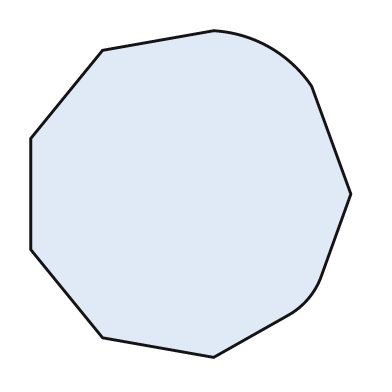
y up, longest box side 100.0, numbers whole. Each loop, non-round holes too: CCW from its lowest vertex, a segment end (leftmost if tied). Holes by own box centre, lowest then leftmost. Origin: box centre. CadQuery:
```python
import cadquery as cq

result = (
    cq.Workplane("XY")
    .moveTo(7.0, -50.0)
    .lineTo(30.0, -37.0)
    .threePointArc((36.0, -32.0), (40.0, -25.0))
    .lineTo(49.0, 0.0)
    .lineTo(37.0, 33.0)
    .threePointArc((24.0, 45.0), (7.0, 50.0))
    .lineTo(-27.0, 44.0)
    .lineTo(-49.0, 17.0)
    .lineTo(-49.0, -17.0)
    .lineTo(-27.0, -44.0)
    .close()
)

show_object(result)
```